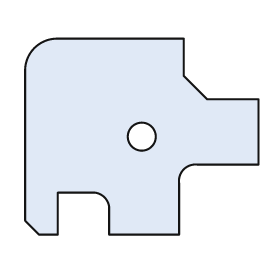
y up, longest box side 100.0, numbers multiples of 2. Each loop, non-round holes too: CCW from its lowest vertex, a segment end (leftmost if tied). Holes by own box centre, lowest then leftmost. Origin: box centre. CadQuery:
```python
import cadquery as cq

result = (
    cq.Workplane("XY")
    .moveTo(-44.0, -42.0)
    .lineTo(-36.0, -42.0)
    .lineTo(-36.0, -24.0)
    .lineTo(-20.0, -24.0)
    .threePointArc((-16.0, -26.0), (-14.0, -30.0))
    .lineTo(-14.0, -42.0)
    .lineTo(16.0, -42.0)
    .lineTo(16.0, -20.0)
    .threePointArc((18.0, -14.0), (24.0, -12.0))
    .lineTo(50.0, -12.0)
    .lineTo(50.0, 16.0)
    .lineTo(28.0, 16.0)
    .lineTo(18.0, 26.0)
    .lineTo(18.0, 42.0)
    .lineTo(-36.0, 42.0)
    .threePointArc((-46.0, 38.0), (-50.0, 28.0))
    .lineTo(-50.0, -36.0)
    .close()
    .moveTo(0.0, 0.0)
    .circle(6.0)
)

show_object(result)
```